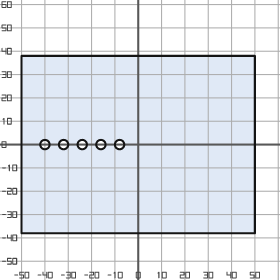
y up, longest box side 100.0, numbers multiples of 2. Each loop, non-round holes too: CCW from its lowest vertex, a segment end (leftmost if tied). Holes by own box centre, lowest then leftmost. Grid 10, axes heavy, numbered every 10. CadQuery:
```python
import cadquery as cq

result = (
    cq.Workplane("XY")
    .moveTo(-50.0, -38.0)
    .lineTo(50.0, -38.0)
    .lineTo(50.0, 38.0)
    .lineTo(-50.0, 38.0)
    .close()
    .moveTo(-40.0, 0.0)
    .circle(2.0)
    .moveTo(-32.0, 0.0)
    .circle(2.0)
    .moveTo(-24.0, 0.0)
    .circle(2.0)
    .moveTo(-16.0, 0.0)
    .circle(2.0)
    .moveTo(-8.0, 0.0)
    .circle(2.0)
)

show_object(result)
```